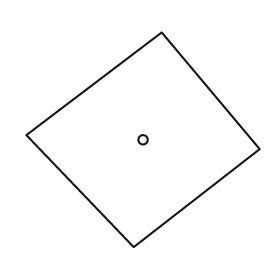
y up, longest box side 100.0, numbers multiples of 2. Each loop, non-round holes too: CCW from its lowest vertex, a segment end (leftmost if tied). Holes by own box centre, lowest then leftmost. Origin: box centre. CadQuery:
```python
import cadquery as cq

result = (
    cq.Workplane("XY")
    .moveTo(-4.0, -46.0)
    .lineTo(50.0, -4.0)
    .lineTo(8.0, 46.0)
    .lineTo(-50.0, 2.0)
    .close()
    .moveTo(0.0, 0.0)
    .circle(2.0)
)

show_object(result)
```